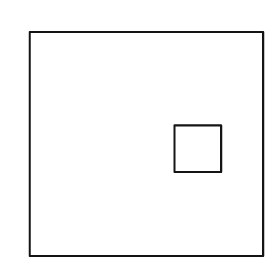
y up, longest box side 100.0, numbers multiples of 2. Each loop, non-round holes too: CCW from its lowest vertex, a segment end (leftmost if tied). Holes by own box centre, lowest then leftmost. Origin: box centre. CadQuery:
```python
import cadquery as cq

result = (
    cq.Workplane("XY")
    .moveTo(-50.0, -48.0)
    .lineTo(50.0, -48.0)
    .lineTo(50.0, 48.0)
    .lineTo(-50.0, 48.0)
    .close()
    .moveTo(12.0, -12.0)
    .lineTo(32.0, -12.0)
    .lineTo(32.0, 8.0)
    .lineTo(12.0, 8.0)
    .close()
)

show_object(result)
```